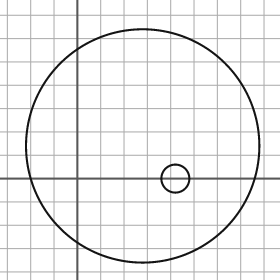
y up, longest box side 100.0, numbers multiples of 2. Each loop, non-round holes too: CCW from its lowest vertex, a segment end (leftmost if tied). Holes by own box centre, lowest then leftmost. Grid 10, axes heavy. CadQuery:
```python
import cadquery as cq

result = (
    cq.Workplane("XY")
    .moveTo(28.0, 14.0)
    .circle(50.0)
    .moveTo(42.0, 0.0)
    .circle(6.0)
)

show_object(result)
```